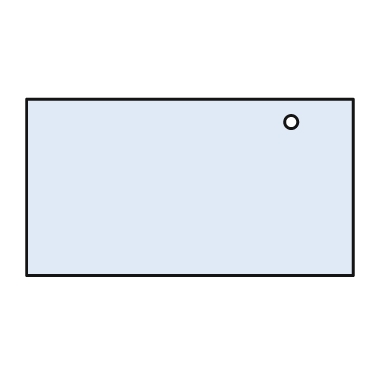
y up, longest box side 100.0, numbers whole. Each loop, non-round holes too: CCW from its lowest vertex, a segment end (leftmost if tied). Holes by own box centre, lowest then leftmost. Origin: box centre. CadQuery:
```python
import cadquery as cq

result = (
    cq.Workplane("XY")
    .moveTo(-50.0, -27.0)
    .lineTo(50.0, -27.0)
    .lineTo(50.0, 27.0)
    .lineTo(-50.0, 27.0)
    .close()
    .moveTo(31.0, 20.0)
    .circle(2.0)
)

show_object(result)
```